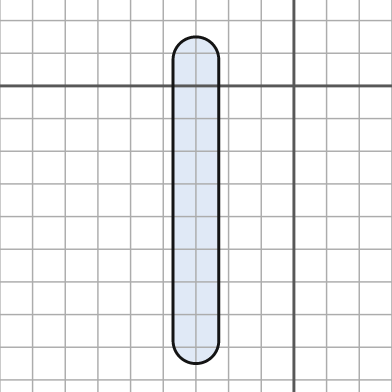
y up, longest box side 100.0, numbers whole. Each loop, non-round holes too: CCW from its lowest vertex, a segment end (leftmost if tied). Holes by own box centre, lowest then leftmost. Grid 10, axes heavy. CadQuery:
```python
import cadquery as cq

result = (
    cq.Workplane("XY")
    .moveTo(-37.0, -78.0)
    .threePointArc((-30.0, -85.0), (-23.0, -78.0))
    .lineTo(-23.0, 8.0)
    .threePointArc((-30.0, 15.0), (-37.0, 8.0))
    .close()
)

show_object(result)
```